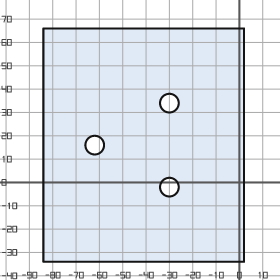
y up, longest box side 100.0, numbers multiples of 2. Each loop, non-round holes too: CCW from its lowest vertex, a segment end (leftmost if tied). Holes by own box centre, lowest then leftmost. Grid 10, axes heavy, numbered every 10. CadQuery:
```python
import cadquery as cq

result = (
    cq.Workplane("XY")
    .moveTo(-84.0, -34.0)
    .lineTo(2.0, -34.0)
    .lineTo(2.0, 66.0)
    .lineTo(-84.0, 66.0)
    .close()
    .moveTo(-30.0, -2.0)
    .circle(4.0)
    .moveTo(-62.0, 16.0)
    .circle(4.0)
    .moveTo(-30.0, 34.0)
    .circle(4.0)
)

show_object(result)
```